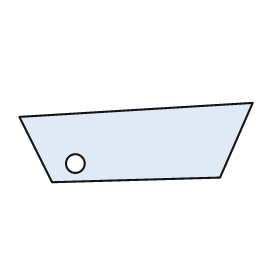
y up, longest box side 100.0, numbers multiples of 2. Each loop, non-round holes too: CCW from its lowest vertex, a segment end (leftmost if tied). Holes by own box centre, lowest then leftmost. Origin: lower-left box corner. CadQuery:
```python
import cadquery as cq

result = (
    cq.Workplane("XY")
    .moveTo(14.0, 0.0)
    .lineTo(86.0, 2.0)
    .lineTo(100.0, 34.0)
    .lineTo(0.0, 28.0)
    .close()
    .moveTo(24.0, 8.0)
    .circle(4.0)
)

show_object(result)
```